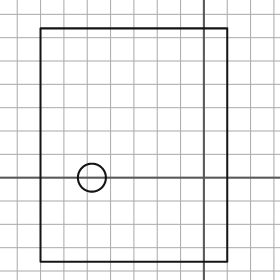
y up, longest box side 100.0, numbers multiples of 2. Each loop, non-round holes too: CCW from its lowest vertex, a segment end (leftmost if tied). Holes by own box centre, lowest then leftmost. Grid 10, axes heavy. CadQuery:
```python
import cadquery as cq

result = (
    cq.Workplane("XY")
    .moveTo(-70.0, -36.0)
    .lineTo(10.0, -36.0)
    .lineTo(10.0, 64.0)
    .lineTo(-70.0, 64.0)
    .close()
    .moveTo(-48.0, 0.0)
    .circle(6.0)
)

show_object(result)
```